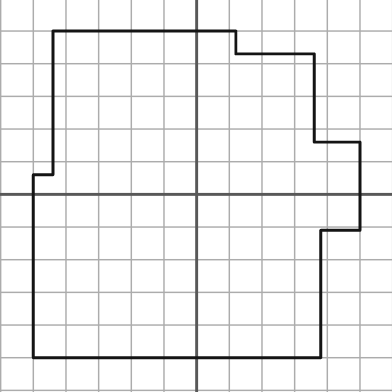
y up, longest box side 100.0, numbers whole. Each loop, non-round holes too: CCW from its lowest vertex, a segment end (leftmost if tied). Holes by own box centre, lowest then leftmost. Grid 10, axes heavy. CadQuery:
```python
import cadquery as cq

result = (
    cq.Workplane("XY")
    .moveTo(-50.0, -50.0)
    .lineTo(38.0, -50.0)
    .lineTo(38.0, -11.0)
    .lineTo(50.0, -11.0)
    .lineTo(50.0, 16.0)
    .lineTo(36.0, 16.0)
    .lineTo(36.0, 43.0)
    .lineTo(12.0, 43.0)
    .lineTo(12.0, 50.0)
    .lineTo(-44.0, 50.0)
    .lineTo(-44.0, 6.0)
    .lineTo(-50.0, 6.0)
    .close()
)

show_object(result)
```